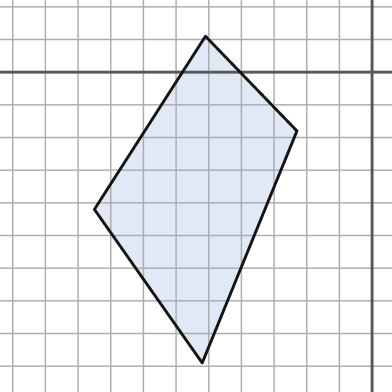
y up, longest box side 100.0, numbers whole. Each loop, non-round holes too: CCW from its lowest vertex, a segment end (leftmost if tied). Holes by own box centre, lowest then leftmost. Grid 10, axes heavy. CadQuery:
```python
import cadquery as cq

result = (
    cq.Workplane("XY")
    .moveTo(-52.0, -89.0)
    .lineTo(-23.0, -18.0)
    .lineTo(-51.0, 11.0)
    .lineTo(-85.0, -42.0)
    .close()
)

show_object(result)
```